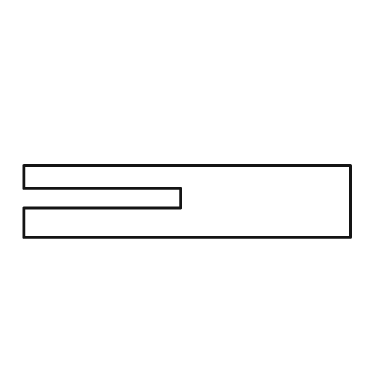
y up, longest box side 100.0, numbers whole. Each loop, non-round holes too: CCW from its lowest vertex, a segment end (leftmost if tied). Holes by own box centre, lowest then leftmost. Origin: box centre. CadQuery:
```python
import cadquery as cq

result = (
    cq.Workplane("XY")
    .moveTo(-50.0, -11.0)
    .lineTo(50.0, -11.0)
    .lineTo(50.0, 11.0)
    .lineTo(-50.0, 11.0)
    .lineTo(-50.0, 4.0)
    .lineTo(-2.0, 4.0)
    .lineTo(-2.0, -2.0)
    .lineTo(-50.0, -2.0)
    .close()
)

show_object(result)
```